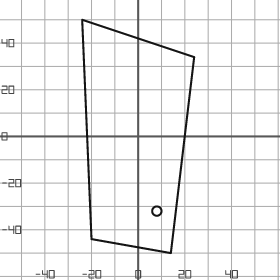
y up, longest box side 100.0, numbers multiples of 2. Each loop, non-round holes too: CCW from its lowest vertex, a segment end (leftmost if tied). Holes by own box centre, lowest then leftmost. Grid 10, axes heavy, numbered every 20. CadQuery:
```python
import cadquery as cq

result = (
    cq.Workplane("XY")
    .moveTo(14.0, -50.0)
    .lineTo(24.0, 34.0)
    .lineTo(-24.0, 50.0)
    .lineTo(-20.0, -44.0)
    .close()
    .moveTo(8.0, -32.0)
    .circle(2.0)
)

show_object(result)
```